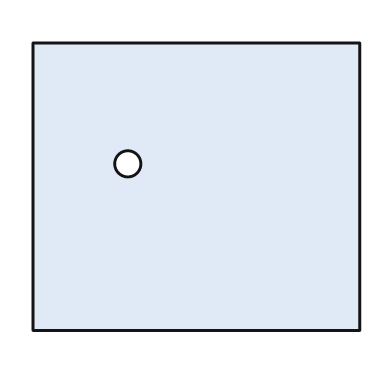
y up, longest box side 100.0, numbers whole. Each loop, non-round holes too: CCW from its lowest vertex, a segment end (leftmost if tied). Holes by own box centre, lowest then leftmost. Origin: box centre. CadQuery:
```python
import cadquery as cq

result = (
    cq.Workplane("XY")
    .moveTo(-50.0, -44.0)
    .lineTo(50.0, -44.0)
    .lineTo(50.0, 44.0)
    .lineTo(-50.0, 44.0)
    .close()
    .moveTo(-21.0, 7.0)
    .circle(4.0)
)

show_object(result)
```